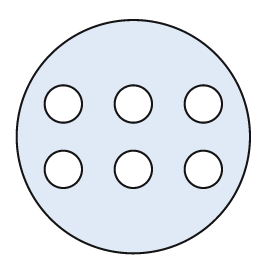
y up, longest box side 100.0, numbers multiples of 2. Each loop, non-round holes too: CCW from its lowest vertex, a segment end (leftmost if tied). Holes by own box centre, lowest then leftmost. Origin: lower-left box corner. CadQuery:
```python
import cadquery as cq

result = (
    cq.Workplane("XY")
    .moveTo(50.0, 50.0)
    .circle(50.0)
    .moveTo(20.0, 36.0)
    .circle(8.0)
    .moveTo(50.0, 36.0)
    .circle(8.0)
    .moveTo(80.0, 36.0)
    .circle(8.0)
    .moveTo(20.0, 64.0)
    .circle(8.0)
    .moveTo(50.0, 64.0)
    .circle(8.0)
    .moveTo(80.0, 64.0)
    .circle(8.0)
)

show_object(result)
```